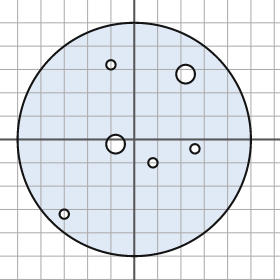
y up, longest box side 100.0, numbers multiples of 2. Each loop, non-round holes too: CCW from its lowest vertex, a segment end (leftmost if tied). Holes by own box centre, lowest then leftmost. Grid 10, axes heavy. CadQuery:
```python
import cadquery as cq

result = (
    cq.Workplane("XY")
    .moveTo(0.0, 0.0)
    .circle(50.0)
    .moveTo(-30.0, -32.0)
    .circle(2.0)
    .moveTo(8.0, -10.0)
    .circle(2.0)
    .moveTo(26.0, -4.0)
    .circle(2.0)
    .moveTo(-8.0, -2.0)
    .circle(4.0)
    .moveTo(22.0, 28.0)
    .circle(4.0)
    .moveTo(-10.0, 32.0)
    .circle(2.0)
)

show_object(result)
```